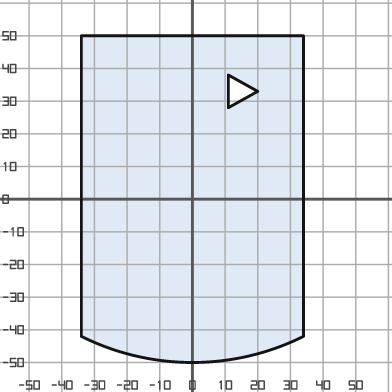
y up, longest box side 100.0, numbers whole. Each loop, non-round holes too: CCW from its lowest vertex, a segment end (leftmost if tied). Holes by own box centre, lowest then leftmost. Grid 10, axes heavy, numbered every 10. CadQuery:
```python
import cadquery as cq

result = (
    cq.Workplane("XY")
    .moveTo(-34.0, -42.0)
    .threePointArc((0.0, -50.0), (34.0, -42.0))
    .lineTo(34.0, 50.0)
    .lineTo(-34.0, 50.0)
    .close()
    .moveTo(11.0, 28.0)
    .lineTo(20.0, 33.0)
    .lineTo(11.0, 38.0)
    .close()
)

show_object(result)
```